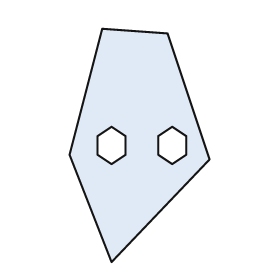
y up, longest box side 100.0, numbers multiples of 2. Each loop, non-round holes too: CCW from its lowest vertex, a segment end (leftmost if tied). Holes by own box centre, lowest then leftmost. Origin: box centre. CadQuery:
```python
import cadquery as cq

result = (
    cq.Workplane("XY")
    .moveTo(-12.0, -50.0)
    .lineTo(30.0, -6.0)
    .lineTo(12.0, 48.0)
    .lineTo(-16.0, 50.0)
    .lineTo(-30.0, -4.0)
    .close()
    .moveTo(-12.0, -8.0)
    .lineTo(-6.0, -4.0)
    .lineTo(-6.0, 4.0)
    .lineTo(-12.0, 8.0)
    .lineTo(-18.0, 4.0)
    .lineTo(-18.0, -4.0)
    .close()
    .moveTo(14.0, -8.0)
    .lineTo(20.0, -4.0)
    .lineTo(20.0, 4.0)
    .lineTo(14.0, 8.0)
    .lineTo(8.0, 4.0)
    .lineTo(8.0, -4.0)
    .close()
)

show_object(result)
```